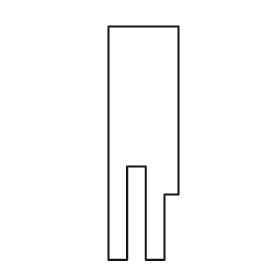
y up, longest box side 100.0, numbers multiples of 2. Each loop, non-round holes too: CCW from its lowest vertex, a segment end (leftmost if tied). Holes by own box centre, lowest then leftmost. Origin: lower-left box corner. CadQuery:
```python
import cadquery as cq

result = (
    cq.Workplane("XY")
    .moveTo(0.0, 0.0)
    .lineTo(8.0, 0.0)
    .lineTo(8.0, 40.0)
    .lineTo(16.0, 40.0)
    .lineTo(16.0, 0.0)
    .lineTo(24.0, 0.0)
    .lineTo(24.0, 28.0)
    .lineTo(30.0, 28.0)
    .lineTo(30.0, 100.0)
    .lineTo(0.0, 100.0)
    .close()
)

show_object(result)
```